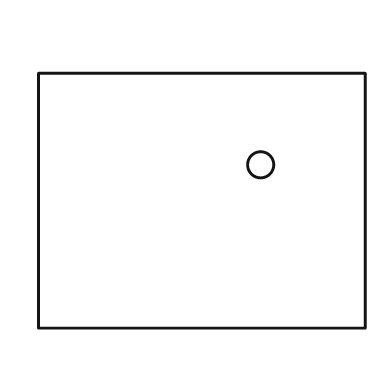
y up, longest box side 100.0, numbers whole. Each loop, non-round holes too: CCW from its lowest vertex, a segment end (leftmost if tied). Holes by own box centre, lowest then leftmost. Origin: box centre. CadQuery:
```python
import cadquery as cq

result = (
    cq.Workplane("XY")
    .moveTo(-50.0, -39.0)
    .lineTo(50.0, -39.0)
    .lineTo(50.0, 39.0)
    .lineTo(-50.0, 39.0)
    .close()
    .moveTo(18.0, 11.0)
    .circle(4.0)
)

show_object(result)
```